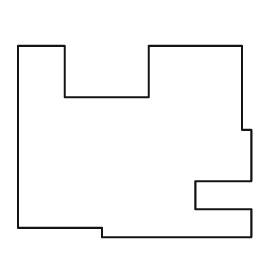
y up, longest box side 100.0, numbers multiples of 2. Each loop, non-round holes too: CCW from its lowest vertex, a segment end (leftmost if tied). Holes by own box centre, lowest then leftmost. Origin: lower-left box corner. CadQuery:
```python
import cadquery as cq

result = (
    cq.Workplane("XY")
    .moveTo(36.0, 0.0)
    .lineTo(100.0, 0.0)
    .lineTo(100.0, 12.0)
    .lineTo(76.0, 12.0)
    .lineTo(76.0, 24.0)
    .lineTo(100.0, 24.0)
    .lineTo(100.0, 46.0)
    .lineTo(96.0, 46.0)
    .lineTo(96.0, 82.0)
    .lineTo(56.0, 82.0)
    .lineTo(56.0, 60.0)
    .lineTo(20.0, 60.0)
    .lineTo(20.0, 82.0)
    .lineTo(0.0, 82.0)
    .lineTo(0.0, 4.0)
    .lineTo(36.0, 4.0)
    .close()
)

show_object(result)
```